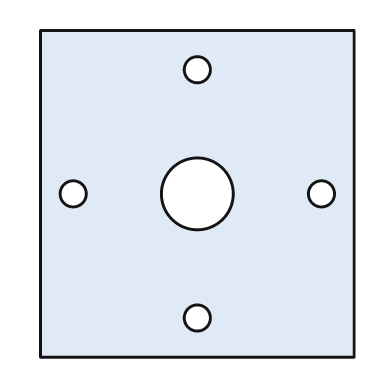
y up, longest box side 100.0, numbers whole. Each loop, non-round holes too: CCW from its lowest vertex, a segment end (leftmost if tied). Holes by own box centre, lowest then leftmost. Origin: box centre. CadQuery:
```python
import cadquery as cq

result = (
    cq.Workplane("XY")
    .moveTo(-48.0, -50.0)
    .lineTo(48.0, -50.0)
    .lineTo(48.0, 50.0)
    .lineTo(-48.0, 50.0)
    .close()
    .moveTo(0.0, -38.0)
    .circle(4.0)
    .moveTo(-38.0, 0.0)
    .circle(4.0)
    .moveTo(0.0, 0.0)
    .circle(11.0)
    .moveTo(38.0, 0.0)
    .circle(4.0)
    .moveTo(0.0, 38.0)
    .circle(4.0)
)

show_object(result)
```